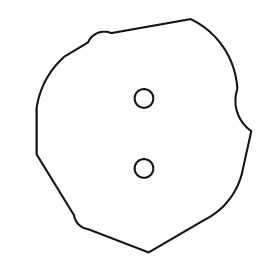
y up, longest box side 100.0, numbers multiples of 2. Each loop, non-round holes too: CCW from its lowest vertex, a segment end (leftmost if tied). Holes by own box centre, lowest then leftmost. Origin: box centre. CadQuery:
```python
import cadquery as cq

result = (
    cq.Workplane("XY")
    .moveTo(2.0, -50.0)
    .lineTo(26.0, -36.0)
    .threePointArc((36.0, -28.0), (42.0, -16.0))
    .lineTo(46.0, 2.0)
    .threePointArc((40.0, 10.0), (40.0, 20.0))
    .threePointArc((34.0, 38.0), (20.0, 50.0))
    .lineTo(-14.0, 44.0)
    .threePointArc((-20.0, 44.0), (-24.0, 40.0))
    .lineTo(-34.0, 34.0)
    .threePointArc((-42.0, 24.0), (-46.0, 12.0))
    .lineTo(-46.0, -8.0)
    .lineTo(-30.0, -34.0)
    .threePointArc((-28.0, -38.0), (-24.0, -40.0))
    .close()
    .moveTo(0.0, -14.0)
    .circle(4.0)
    .moveTo(0.0, 16.0)
    .circle(4.0)
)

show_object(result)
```